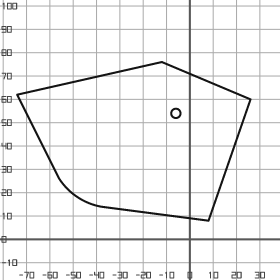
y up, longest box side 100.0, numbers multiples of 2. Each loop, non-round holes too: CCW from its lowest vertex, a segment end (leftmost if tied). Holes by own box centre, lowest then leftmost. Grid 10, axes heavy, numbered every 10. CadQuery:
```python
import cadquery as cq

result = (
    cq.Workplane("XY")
    .moveTo(8.0, 8.0)
    .lineTo(26.0, 60.0)
    .lineTo(-12.0, 76.0)
    .lineTo(-74.0, 62.0)
    .lineTo(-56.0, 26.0)
    .threePointArc((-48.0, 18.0), (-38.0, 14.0))
    .close()
    .moveTo(-6.0, 54.0)
    .circle(2.0)
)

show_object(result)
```